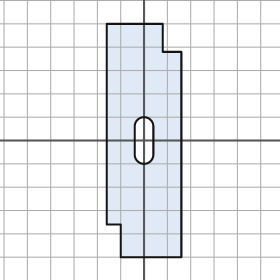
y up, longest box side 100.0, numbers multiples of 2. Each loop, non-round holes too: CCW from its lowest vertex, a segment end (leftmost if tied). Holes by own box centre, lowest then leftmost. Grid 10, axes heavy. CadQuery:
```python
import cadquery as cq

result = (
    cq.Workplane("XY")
    .moveTo(-10.0, -50.0)
    .lineTo(16.0, -50.0)
    .lineTo(16.0, 38.0)
    .lineTo(8.0, 38.0)
    .lineTo(8.0, 50.0)
    .lineTo(-16.0, 50.0)
    .lineTo(-16.0, -36.0)
    .lineTo(-10.0, -36.0)
    .close()
    .moveTo(-4.0, -6.0)
    .threePointArc((0.0, -10.0), (4.0, -6.0))
    .lineTo(4.0, 6.0)
    .threePointArc((0.0, 10.0), (-4.0, 6.0))
    .close()
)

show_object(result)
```